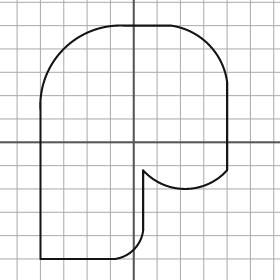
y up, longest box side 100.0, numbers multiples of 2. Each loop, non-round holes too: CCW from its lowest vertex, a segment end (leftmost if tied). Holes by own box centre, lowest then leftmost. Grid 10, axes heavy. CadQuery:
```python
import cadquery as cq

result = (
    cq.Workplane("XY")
    .moveTo(-40.0, -50.0)
    .lineTo(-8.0, -50.0)
    .threePointArc((0.0, -46.0), (4.0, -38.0))
    .lineTo(4.0, -12.0)
    .threePointArc((22.0, -20.0), (40.0, -12.0))
    .lineTo(40.0, 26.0)
    .threePointArc((32.0, 42.0), (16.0, 50.0))
    .lineTo(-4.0, 50.0)
    .threePointArc((-30.0, 40.0), (-40.0, 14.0))
    .close()
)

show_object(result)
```